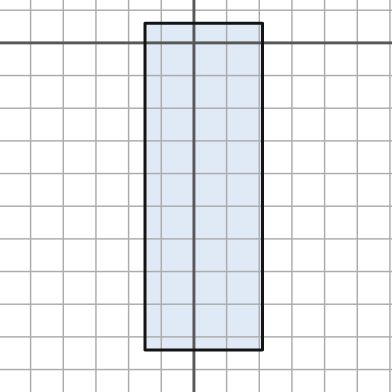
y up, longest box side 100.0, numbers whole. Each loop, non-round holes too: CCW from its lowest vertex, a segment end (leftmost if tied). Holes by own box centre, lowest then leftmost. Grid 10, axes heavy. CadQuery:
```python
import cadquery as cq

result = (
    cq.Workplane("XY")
    .moveTo(-15.0, -94.0)
    .lineTo(21.0, -94.0)
    .lineTo(21.0, 6.0)
    .lineTo(-15.0, 6.0)
    .close()
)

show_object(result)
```